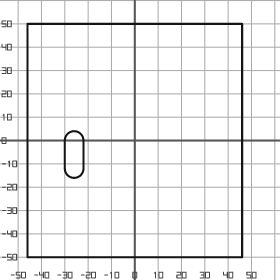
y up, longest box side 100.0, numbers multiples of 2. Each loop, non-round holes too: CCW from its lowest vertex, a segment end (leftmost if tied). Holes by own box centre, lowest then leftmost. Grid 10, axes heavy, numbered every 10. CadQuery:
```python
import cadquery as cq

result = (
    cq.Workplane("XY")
    .moveTo(-46.0, -50.0)
    .lineTo(46.0, -50.0)
    .lineTo(46.0, 50.0)
    .lineTo(-46.0, 50.0)
    .close()
    .moveTo(-30.0, -12.0)
    .threePointArc((-26.0, -16.0), (-22.0, -12.0))
    .lineTo(-22.0, 0.0)
    .threePointArc((-26.0, 4.0), (-30.0, 0.0))
    .close()
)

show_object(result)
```